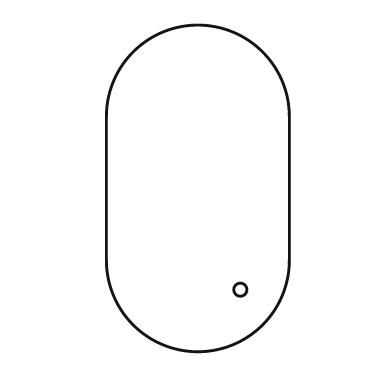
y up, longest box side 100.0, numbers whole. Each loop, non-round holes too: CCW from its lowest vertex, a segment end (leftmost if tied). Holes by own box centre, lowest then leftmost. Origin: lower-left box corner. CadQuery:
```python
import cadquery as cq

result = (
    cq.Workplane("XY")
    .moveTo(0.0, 28.0)
    .threePointArc((28.0, 0.0), (56.0, 28.0))
    .lineTo(56.0, 72.0)
    .threePointArc((28.0, 100.0), (0.0, 72.0))
    .close()
    .moveTo(41.0, 19.0)
    .circle(2.0)
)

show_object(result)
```